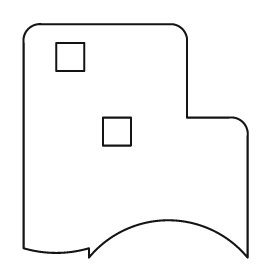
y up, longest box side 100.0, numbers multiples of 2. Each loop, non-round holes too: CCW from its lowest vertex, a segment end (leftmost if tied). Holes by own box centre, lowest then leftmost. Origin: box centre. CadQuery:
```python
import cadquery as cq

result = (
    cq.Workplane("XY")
    .moveTo(-20.0, -50.0)
    .threePointArc((14.0, -34.0), (48.0, -50.0))
    .lineTo(48.0, 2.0)
    .threePointArc((46.0, 8.0), (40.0, 10.0))
    .lineTo(22.0, 10.0)
    .lineTo(22.0, 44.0)
    .threePointArc((20.0, 48.0), (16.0, 50.0))
    .lineTo(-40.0, 50.0)
    .threePointArc((-46.0, 48.0), (-48.0, 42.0))
    .lineTo(-48.0, -46.0)
    .threePointArc((-34.0, -48.0), (-20.0, -46.0))
    .close()
    .moveTo(-14.0, -2.0)
    .lineTo(-2.0, -2.0)
    .lineTo(-2.0, 10.0)
    .lineTo(-14.0, 10.0)
    .close()
    .moveTo(-34.0, 30.0)
    .lineTo(-22.0, 30.0)
    .lineTo(-22.0, 42.0)
    .lineTo(-34.0, 42.0)
    .close()
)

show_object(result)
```